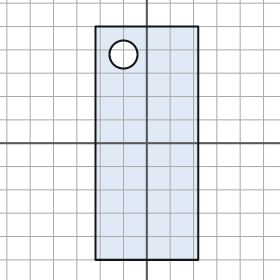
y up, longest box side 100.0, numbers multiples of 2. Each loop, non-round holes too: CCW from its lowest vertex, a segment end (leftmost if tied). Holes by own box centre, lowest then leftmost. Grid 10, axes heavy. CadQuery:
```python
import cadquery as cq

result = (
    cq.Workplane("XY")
    .moveTo(-22.0, -50.0)
    .lineTo(22.0, -50.0)
    .lineTo(22.0, 50.0)
    .lineTo(-22.0, 50.0)
    .close()
    .moveTo(-10.0, 38.0)
    .circle(6.0)
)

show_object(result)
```